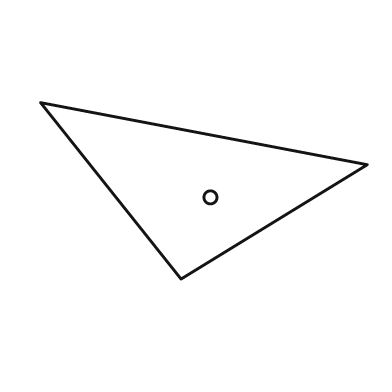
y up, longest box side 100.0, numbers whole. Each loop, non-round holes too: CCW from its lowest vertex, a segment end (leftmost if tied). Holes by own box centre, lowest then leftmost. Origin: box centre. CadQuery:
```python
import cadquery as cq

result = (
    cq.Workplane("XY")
    .moveTo(-7.0, -27.0)
    .lineTo(50.0, 8.0)
    .lineTo(-50.0, 27.0)
    .close()
    .moveTo(2.0, -2.0)
    .circle(2.0)
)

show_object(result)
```